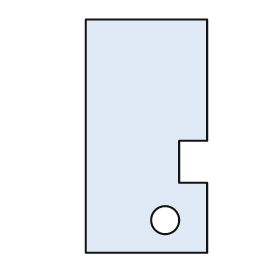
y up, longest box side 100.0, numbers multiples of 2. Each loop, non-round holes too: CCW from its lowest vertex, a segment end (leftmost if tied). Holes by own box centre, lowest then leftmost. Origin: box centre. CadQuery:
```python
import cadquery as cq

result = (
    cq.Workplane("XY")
    .moveTo(-26.0, -50.0)
    .lineTo(26.0, -50.0)
    .lineTo(26.0, -20.0)
    .lineTo(14.0, -20.0)
    .lineTo(14.0, -2.0)
    .lineTo(26.0, -2.0)
    .lineTo(26.0, 50.0)
    .lineTo(-26.0, 50.0)
    .close()
    .moveTo(8.0, -36.0)
    .circle(6.0)
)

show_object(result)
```